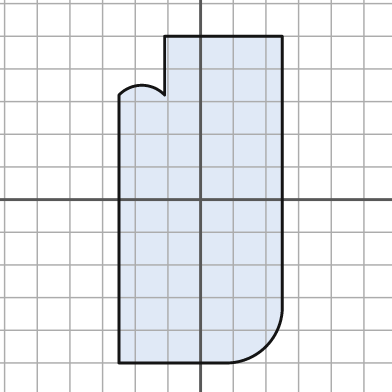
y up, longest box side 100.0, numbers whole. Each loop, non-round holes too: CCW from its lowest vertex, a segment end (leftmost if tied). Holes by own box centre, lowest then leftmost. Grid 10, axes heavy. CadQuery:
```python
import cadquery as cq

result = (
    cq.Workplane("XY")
    .moveTo(-25.0, -50.0)
    .lineTo(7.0, -50.0)
    .threePointArc((20.0, -45.0), (25.0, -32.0))
    .lineTo(25.0, 50.0)
    .lineTo(-11.0, 50.0)
    .lineTo(-11.0, 32.0)
    .threePointArc((-18.0, 35.0), (-25.0, 32.0))
    .close()
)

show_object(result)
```